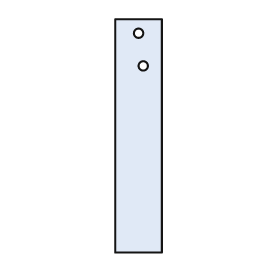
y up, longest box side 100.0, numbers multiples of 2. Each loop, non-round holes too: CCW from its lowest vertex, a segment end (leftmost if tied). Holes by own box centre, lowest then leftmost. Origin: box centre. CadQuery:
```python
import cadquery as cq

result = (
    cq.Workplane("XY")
    .moveTo(-10.0, -50.0)
    .lineTo(10.0, -50.0)
    .lineTo(10.0, 50.0)
    .lineTo(-10.0, 50.0)
    .close()
    .moveTo(2.0, 30.0)
    .circle(2.0)
    .moveTo(0.0, 44.0)
    .circle(2.0)
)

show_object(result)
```